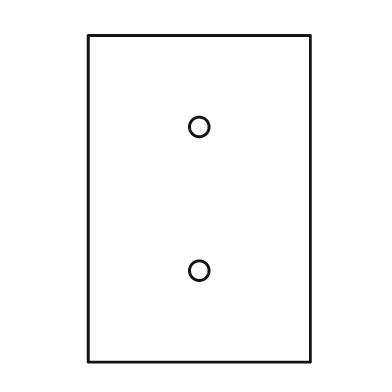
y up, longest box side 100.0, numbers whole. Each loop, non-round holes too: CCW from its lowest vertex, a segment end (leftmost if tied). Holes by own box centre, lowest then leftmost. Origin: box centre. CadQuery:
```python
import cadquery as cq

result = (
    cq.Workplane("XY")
    .moveTo(-34.0, -50.0)
    .lineTo(34.0, -50.0)
    .lineTo(34.0, 50.0)
    .lineTo(-34.0, 50.0)
    .close()
    .moveTo(0.0, -22.0)
    .circle(3.0)
    .moveTo(0.0, 22.0)
    .circle(3.0)
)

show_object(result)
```